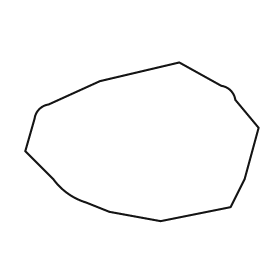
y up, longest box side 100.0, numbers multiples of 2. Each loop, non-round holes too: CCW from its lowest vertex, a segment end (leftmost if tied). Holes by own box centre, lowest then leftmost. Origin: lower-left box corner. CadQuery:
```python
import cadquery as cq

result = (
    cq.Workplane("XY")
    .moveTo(58.0, 0.0)
    .lineTo(88.0, 6.0)
    .lineTo(94.0, 18.0)
    .lineTo(100.0, 40.0)
    .lineTo(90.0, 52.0)
    .threePointArc((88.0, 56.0), (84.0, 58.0))
    .lineTo(66.0, 68.0)
    .lineTo(32.0, 60.0)
    .lineTo(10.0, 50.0)
    .threePointArc((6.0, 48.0), (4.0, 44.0))
    .lineTo(0.0, 30.0)
    .lineTo(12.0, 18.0)
    .threePointArc((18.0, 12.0), (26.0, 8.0))
    .lineTo(36.0, 4.0)
    .close()
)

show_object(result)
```